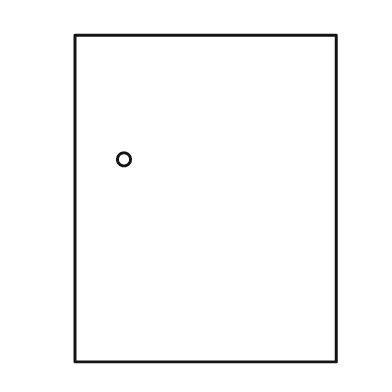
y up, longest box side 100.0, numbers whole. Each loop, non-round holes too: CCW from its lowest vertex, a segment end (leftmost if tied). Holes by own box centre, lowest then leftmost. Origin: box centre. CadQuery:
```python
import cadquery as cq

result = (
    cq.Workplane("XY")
    .moveTo(-40.0, -50.0)
    .lineTo(40.0, -50.0)
    .lineTo(40.0, 50.0)
    .lineTo(-40.0, 50.0)
    .close()
    .moveTo(-25.0, 12.0)
    .circle(2.0)
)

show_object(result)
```